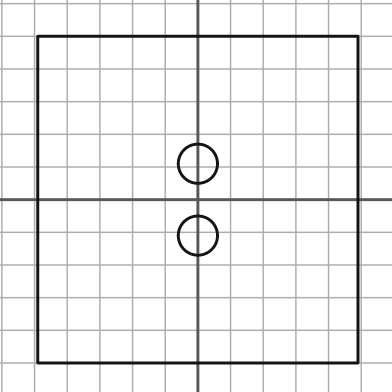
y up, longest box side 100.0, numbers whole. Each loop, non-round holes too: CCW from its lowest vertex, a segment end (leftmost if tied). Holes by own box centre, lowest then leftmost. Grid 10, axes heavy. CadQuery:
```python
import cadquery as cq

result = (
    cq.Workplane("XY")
    .moveTo(-49.0, -50.0)
    .lineTo(49.0, -50.0)
    .lineTo(49.0, 50.0)
    .lineTo(-49.0, 50.0)
    .close()
    .moveTo(0.0, -11.0)
    .circle(6.0)
    .moveTo(0.0, 11.0)
    .circle(6.0)
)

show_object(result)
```